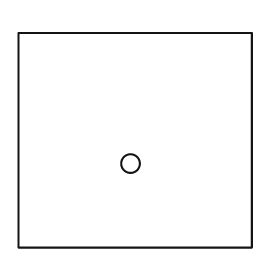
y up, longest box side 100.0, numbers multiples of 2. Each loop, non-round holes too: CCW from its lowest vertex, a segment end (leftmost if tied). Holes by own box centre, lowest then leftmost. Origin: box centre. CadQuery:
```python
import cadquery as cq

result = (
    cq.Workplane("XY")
    .moveTo(-50.0, -46.0)
    .lineTo(50.0, -46.0)
    .lineTo(50.0, 46.0)
    .lineTo(-50.0, 46.0)
    .close()
    .moveTo(-2.0, -10.0)
    .circle(4.0)
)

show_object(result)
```